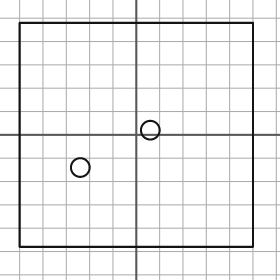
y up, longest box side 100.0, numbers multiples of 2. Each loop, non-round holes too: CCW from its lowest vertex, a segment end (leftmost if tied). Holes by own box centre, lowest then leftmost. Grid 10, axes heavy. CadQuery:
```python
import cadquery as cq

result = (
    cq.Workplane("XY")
    .moveTo(-50.0, -48.0)
    .lineTo(50.0, -48.0)
    .lineTo(50.0, 48.0)
    .lineTo(-50.0, 48.0)
    .close()
    .moveTo(-24.0, -14.0)
    .circle(4.0)
    .moveTo(6.0, 2.0)
    .circle(4.0)
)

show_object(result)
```